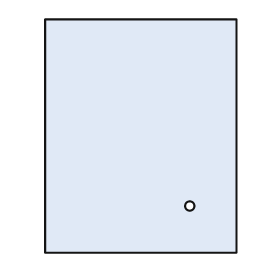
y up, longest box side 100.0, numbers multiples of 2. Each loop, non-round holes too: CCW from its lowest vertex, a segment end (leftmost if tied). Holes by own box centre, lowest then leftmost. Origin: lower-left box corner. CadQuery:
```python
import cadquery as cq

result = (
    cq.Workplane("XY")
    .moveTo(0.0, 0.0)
    .lineTo(82.0, 0.0)
    .lineTo(82.0, 100.0)
    .lineTo(0.0, 100.0)
    .close()
    .moveTo(62.0, 20.0)
    .circle(2.0)
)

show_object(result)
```